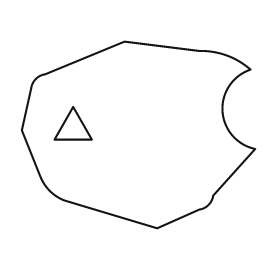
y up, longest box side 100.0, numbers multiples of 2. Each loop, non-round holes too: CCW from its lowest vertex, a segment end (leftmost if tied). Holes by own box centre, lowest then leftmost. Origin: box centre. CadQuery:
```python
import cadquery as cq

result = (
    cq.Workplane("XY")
    .moveTo(8.0, -40.0)
    .lineTo(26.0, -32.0)
    .threePointArc((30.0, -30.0), (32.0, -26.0))
    .lineTo(50.0, -6.0)
    .threePointArc((36.0, 10.0), (48.0, 28.0))
    .threePointArc((38.0, 34.0), (26.0, 36.0))
    .lineTo(-6.0, 40.0)
    .lineTo(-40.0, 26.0)
    .threePointArc((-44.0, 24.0), (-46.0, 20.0))
    .lineTo(-50.0, 2.0)
    .lineTo(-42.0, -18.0)
    .threePointArc((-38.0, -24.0), (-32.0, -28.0))
    .close()
    .moveTo(-36.0, -2.0)
    .lineTo(-20.0, -2.0)
    .lineTo(-28.0, 12.0)
    .close()
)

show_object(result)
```